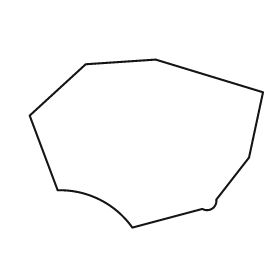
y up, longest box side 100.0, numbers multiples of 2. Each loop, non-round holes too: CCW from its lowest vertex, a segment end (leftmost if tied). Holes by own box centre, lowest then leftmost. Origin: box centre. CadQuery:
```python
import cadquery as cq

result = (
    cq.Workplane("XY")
    .moveTo(-6.0, -36.0)
    .lineTo(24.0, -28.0)
    .threePointArc((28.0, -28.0), (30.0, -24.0))
    .lineTo(44.0, -6.0)
    .lineTo(50.0, 22.0)
    .lineTo(4.0, 36.0)
    .lineTo(-26.0, 34.0)
    .lineTo(-50.0, 12.0)
    .lineTo(-38.0, -20.0)
    .threePointArc((-20.0, -24.0), (-6.0, -36.0))
    .close()
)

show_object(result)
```